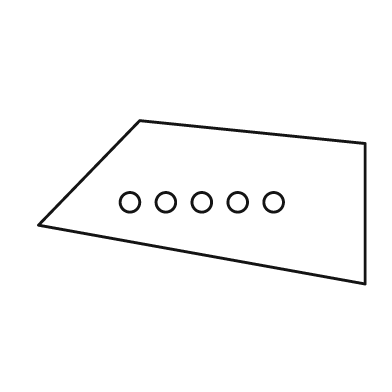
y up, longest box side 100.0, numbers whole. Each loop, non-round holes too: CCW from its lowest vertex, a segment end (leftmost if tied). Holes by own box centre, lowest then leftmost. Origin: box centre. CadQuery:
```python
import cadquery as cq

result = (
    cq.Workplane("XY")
    .moveTo(50.0, -25.0)
    .lineTo(50.0, 18.0)
    .lineTo(-19.0, 25.0)
    .lineTo(-50.0, -7.0)
    .close()
    .moveTo(-22.0, 0.0)
    .circle(3.0)
    .moveTo(-11.0, 0.0)
    .circle(3.0)
    .moveTo(0.0, 0.0)
    .circle(3.0)
    .moveTo(11.0, 0.0)
    .circle(3.0)
    .moveTo(22.0, 0.0)
    .circle(3.0)
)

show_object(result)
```